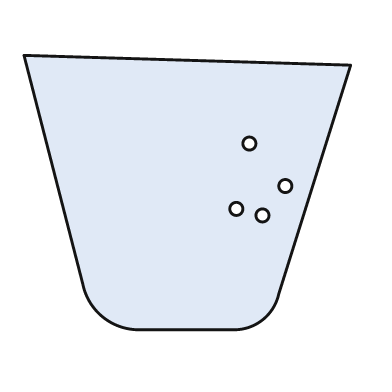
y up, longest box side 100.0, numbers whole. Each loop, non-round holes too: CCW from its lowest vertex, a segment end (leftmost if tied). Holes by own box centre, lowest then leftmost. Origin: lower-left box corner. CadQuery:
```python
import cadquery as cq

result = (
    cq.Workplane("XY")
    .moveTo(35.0, 0.0)
    .lineTo(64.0, 0.0)
    .threePointArc((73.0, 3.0), (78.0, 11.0))
    .lineTo(100.0, 81.0)
    .lineTo(0.0, 84.0)
    .lineTo(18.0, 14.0)
    .threePointArc((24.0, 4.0), (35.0, 0.0))
    .close()
    .moveTo(73.0, 35.0)
    .circle(2.0)
    .moveTo(65.0, 37.0)
    .circle(2.0)
    .moveTo(80.0, 44.0)
    .circle(2.0)
    .moveTo(69.0, 57.0)
    .circle(2.0)
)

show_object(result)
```